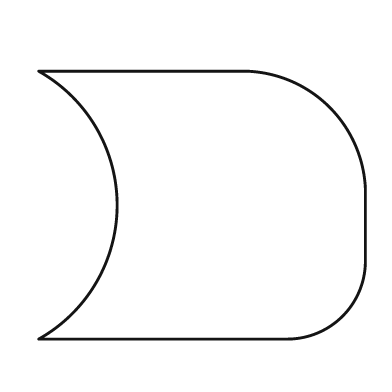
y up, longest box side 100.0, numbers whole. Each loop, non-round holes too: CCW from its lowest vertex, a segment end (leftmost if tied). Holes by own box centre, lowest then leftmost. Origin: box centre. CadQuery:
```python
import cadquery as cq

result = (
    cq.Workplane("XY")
    .moveTo(-50.0, -41.0)
    .lineTo(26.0, -41.0)
    .threePointArc((43.0, -34.0), (50.0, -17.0))
    .lineTo(50.0, 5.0)
    .threePointArc((39.0, 30.0), (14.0, 41.0))
    .lineTo(-50.0, 41.0)
    .threePointArc((-26.0, 0.0), (-50.0, -41.0))
    .close()
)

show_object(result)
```